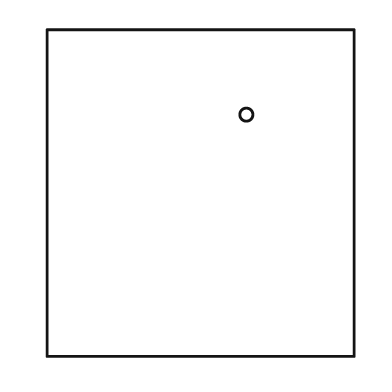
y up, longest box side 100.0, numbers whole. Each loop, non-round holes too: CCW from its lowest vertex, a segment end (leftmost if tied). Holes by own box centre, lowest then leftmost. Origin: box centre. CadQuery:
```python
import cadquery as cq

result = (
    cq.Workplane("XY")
    .moveTo(-47.0, -50.0)
    .lineTo(47.0, -50.0)
    .lineTo(47.0, 50.0)
    .lineTo(-47.0, 50.0)
    .close()
    .moveTo(14.0, 24.0)
    .circle(2.0)
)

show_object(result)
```